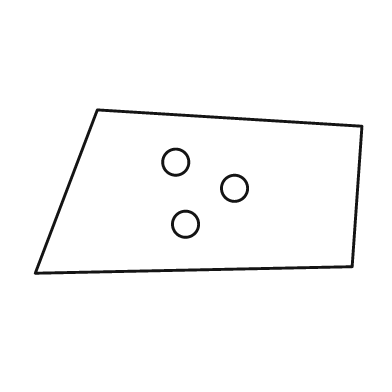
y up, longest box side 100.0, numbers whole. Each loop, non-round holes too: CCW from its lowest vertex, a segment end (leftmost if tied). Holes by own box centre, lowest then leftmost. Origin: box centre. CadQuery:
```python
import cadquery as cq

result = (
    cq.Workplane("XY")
    .moveTo(-50.0, -25.0)
    .lineTo(47.0, -23.0)
    .lineTo(50.0, 20.0)
    .lineTo(-31.0, 25.0)
    .close()
    .moveTo(-4.0, -10.0)
    .circle(4.0)
    .moveTo(11.0, 1.0)
    .circle(4.0)
    .moveTo(-7.0, 9.0)
    .circle(4.0)
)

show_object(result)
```